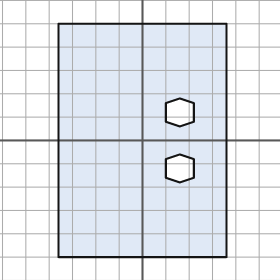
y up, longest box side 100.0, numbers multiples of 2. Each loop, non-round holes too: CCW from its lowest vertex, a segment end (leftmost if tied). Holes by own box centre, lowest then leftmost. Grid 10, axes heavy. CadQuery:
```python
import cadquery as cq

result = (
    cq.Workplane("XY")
    .moveTo(-36.0, -50.0)
    .lineTo(36.0, -50.0)
    .lineTo(36.0, 50.0)
    .lineTo(-36.0, 50.0)
    .close()
    .moveTo(16.0, -18.0)
    .lineTo(22.0, -16.0)
    .lineTo(22.0, -8.0)
    .lineTo(16.0, -6.0)
    .lineTo(10.0, -8.0)
    .lineTo(10.0, -16.0)
    .close()
    .moveTo(16.0, 6.0)
    .lineTo(22.0, 8.0)
    .lineTo(22.0, 16.0)
    .lineTo(16.0, 18.0)
    .lineTo(10.0, 16.0)
    .lineTo(10.0, 8.0)
    .close()
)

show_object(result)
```